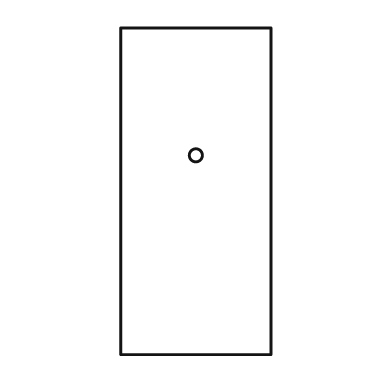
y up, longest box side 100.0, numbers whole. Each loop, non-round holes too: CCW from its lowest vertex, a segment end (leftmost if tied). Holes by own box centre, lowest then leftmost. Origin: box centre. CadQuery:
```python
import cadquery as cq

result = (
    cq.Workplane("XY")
    .moveTo(-23.0, -50.0)
    .lineTo(23.0, -50.0)
    .lineTo(23.0, 50.0)
    .lineTo(-23.0, 50.0)
    .close()
    .moveTo(0.0, 11.0)
    .circle(2.0)
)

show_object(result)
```